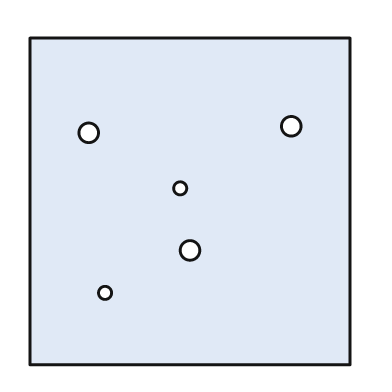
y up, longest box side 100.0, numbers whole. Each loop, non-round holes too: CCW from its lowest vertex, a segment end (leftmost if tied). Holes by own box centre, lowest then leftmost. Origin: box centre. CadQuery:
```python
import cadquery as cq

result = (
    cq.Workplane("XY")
    .moveTo(-49.0, -50.0)
    .lineTo(49.0, -50.0)
    .lineTo(49.0, 50.0)
    .lineTo(-49.0, 50.0)
    .close()
    .moveTo(-26.0, -28.0)
    .circle(2.0)
    .moveTo(0.0, -15.0)
    .circle(3.0)
    .moveTo(-3.0, 4.0)
    .circle(2.0)
    .moveTo(-31.0, 21.0)
    .circle(3.0)
    .moveTo(31.0, 23.0)
    .circle(3.0)
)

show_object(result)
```